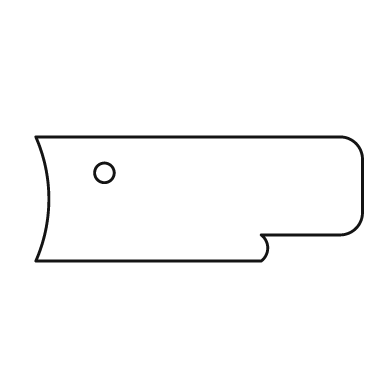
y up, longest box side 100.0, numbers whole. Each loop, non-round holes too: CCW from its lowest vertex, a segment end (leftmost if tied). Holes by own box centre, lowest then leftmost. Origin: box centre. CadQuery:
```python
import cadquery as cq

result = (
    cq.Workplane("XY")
    .moveTo(-50.0, -19.0)
    .lineTo(19.0, -19.0)
    .threePointArc((21.0, -15.0), (19.0, -11.0))
    .lineTo(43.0, -11.0)
    .threePointArc((48.0, -9.0), (50.0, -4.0))
    .lineTo(50.0, 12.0)
    .threePointArc((48.0, 17.0), (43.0, 19.0))
    .lineTo(-50.0, 19.0)
    .threePointArc((-46.0, 0.0), (-50.0, -19.0))
    .close()
    .moveTo(-29.0, 8.0)
    .circle(3.0)
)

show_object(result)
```